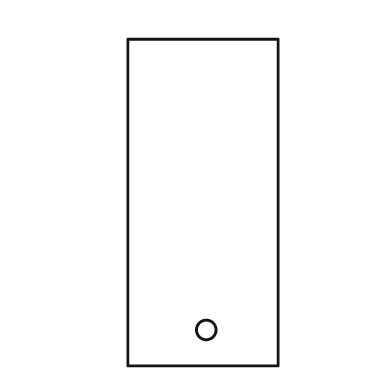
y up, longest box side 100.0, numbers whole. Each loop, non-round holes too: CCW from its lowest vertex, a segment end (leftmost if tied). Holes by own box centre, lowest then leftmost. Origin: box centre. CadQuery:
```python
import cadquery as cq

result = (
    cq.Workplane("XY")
    .moveTo(-23.0, -50.0)
    .lineTo(23.0, -50.0)
    .lineTo(23.0, 50.0)
    .lineTo(-23.0, 50.0)
    .close()
    .moveTo(1.0, -39.0)
    .circle(3.0)
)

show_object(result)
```